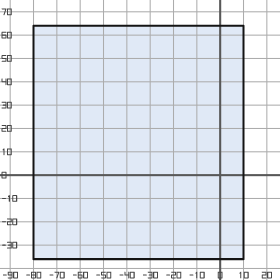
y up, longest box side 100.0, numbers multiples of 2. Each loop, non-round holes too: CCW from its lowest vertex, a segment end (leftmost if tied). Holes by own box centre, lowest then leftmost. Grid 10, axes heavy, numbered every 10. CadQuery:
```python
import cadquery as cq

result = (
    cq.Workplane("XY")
    .moveTo(-80.0, -36.0)
    .lineTo(10.0, -36.0)
    .lineTo(10.0, 64.0)
    .lineTo(-80.0, 64.0)
    .close()
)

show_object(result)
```